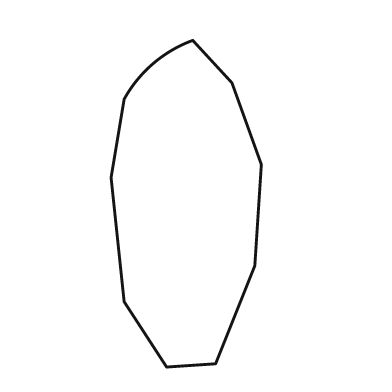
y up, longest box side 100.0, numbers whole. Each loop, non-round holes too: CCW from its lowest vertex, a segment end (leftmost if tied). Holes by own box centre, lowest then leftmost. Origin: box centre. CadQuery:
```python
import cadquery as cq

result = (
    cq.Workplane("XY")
    .moveTo(-6.0, -50.0)
    .lineTo(9.0, -49.0)
    .lineTo(21.0, -19.0)
    .lineTo(23.0, 12.0)
    .lineTo(14.0, 37.0)
    .lineTo(2.0, 50.0)
    .threePointArc((-10.0, 43.0), (-19.0, 32.0))
    .lineTo(-23.0, 8.0)
    .lineTo(-19.0, -30.0)
    .close()
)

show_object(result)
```